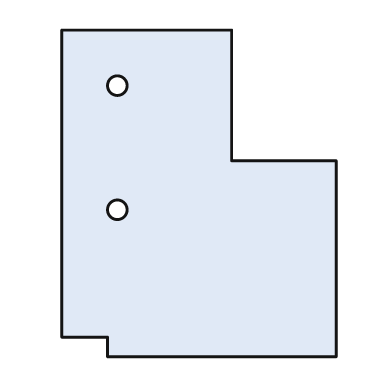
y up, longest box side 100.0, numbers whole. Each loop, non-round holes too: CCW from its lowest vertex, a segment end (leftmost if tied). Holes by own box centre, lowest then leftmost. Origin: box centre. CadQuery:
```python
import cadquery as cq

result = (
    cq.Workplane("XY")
    .moveTo(-28.0, -50.0)
    .lineTo(42.0, -50.0)
    .lineTo(42.0, 10.0)
    .lineTo(10.0, 10.0)
    .lineTo(10.0, 50.0)
    .lineTo(-42.0, 50.0)
    .lineTo(-42.0, -44.0)
    .lineTo(-28.0, -44.0)
    .close()
    .moveTo(-25.0, -5.0)
    .circle(3.0)
    .moveTo(-25.0, 33.0)
    .circle(3.0)
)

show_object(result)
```